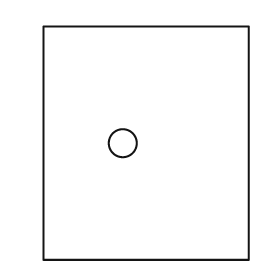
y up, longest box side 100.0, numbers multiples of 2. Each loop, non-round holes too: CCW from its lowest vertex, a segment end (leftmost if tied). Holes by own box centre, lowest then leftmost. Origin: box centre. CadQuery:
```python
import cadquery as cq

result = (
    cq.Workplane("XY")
    .moveTo(-44.0, -50.0)
    .lineTo(44.0, -50.0)
    .lineTo(44.0, 50.0)
    .lineTo(-44.0, 50.0)
    .close()
    .moveTo(-10.0, 0.0)
    .circle(6.0)
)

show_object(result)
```